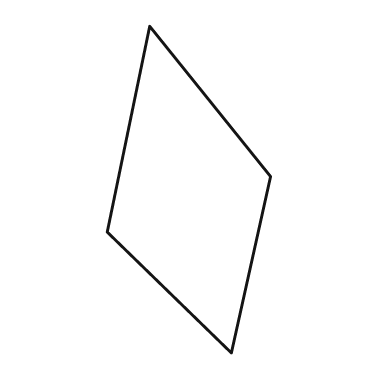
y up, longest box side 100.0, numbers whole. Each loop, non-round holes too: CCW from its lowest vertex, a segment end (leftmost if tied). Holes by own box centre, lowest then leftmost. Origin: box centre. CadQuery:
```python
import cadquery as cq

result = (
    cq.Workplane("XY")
    .moveTo(13.0, -50.0)
    .lineTo(25.0, 4.0)
    .lineTo(-12.0, 50.0)
    .lineTo(-25.0, -13.0)
    .close()
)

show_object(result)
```